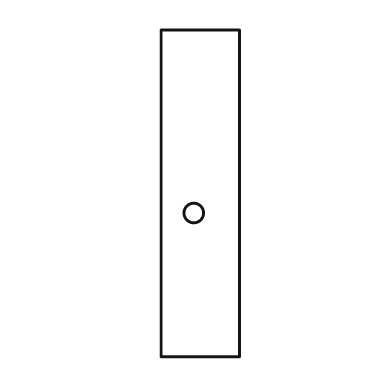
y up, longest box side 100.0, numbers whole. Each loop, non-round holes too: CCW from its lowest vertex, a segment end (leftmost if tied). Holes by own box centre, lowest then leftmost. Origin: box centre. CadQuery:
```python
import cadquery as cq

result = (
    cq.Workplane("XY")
    .moveTo(-12.0, -50.0)
    .lineTo(12.0, -50.0)
    .lineTo(12.0, 50.0)
    .lineTo(-12.0, 50.0)
    .close()
    .moveTo(-2.0, -6.0)
    .circle(3.0)
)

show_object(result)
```